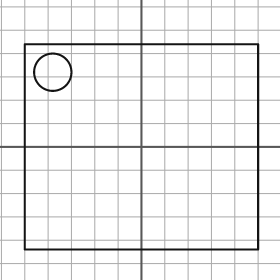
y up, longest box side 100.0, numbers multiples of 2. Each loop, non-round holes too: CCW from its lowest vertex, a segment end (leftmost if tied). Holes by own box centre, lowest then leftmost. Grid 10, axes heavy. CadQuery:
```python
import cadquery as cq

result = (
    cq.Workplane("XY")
    .moveTo(-50.0, -44.0)
    .lineTo(50.0, -44.0)
    .lineTo(50.0, 44.0)
    .lineTo(-50.0, 44.0)
    .close()
    .moveTo(-38.0, 32.0)
    .circle(8.0)
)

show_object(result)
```